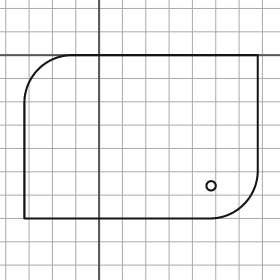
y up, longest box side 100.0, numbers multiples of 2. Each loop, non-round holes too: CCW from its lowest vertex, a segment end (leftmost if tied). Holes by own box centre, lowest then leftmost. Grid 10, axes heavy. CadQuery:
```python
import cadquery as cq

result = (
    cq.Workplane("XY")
    .moveTo(-32.0, -70.0)
    .lineTo(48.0, -70.0)
    .threePointArc((62.0, -64.0), (68.0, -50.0))
    .lineTo(68.0, 0.0)
    .lineTo(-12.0, 0.0)
    .threePointArc((-26.0, -6.0), (-32.0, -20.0))
    .close()
    .moveTo(48.0, -56.0)
    .circle(2.0)
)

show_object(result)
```